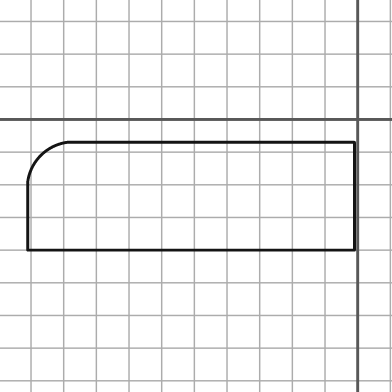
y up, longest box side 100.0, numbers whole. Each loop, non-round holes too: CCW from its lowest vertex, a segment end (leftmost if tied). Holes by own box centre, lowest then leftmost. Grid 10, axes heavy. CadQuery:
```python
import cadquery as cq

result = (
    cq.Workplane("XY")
    .moveTo(-101.0, -40.0)
    .lineTo(-1.0, -40.0)
    .lineTo(-1.0, -7.0)
    .lineTo(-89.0, -7.0)
    .threePointArc((-97.0, -11.0), (-101.0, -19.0))
    .close()
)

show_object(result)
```